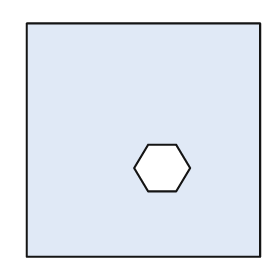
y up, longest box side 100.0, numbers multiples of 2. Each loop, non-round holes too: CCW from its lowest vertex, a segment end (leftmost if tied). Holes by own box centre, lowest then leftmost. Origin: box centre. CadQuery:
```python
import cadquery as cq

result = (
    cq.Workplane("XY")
    .moveTo(-50.0, -50.0)
    .lineTo(50.0, -50.0)
    .lineTo(50.0, 50.0)
    .lineTo(-50.0, 50.0)
    .close()
    .moveTo(2.0, -22.0)
    .lineTo(14.0, -22.0)
    .lineTo(20.0, -12.0)
    .lineTo(14.0, -2.0)
    .lineTo(2.0, -2.0)
    .lineTo(-4.0, -12.0)
    .close()
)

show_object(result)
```